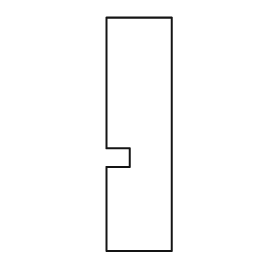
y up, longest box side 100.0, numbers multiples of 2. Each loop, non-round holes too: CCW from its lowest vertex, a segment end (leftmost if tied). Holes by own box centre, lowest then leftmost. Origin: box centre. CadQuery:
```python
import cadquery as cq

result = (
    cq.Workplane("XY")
    .moveTo(-14.0, -50.0)
    .lineTo(14.0, -50.0)
    .lineTo(14.0, 50.0)
    .lineTo(-14.0, 50.0)
    .lineTo(-14.0, -6.0)
    .lineTo(-4.0, -6.0)
    .lineTo(-4.0, -14.0)
    .lineTo(-14.0, -14.0)
    .close()
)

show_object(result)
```